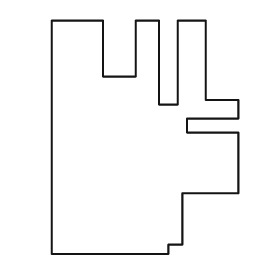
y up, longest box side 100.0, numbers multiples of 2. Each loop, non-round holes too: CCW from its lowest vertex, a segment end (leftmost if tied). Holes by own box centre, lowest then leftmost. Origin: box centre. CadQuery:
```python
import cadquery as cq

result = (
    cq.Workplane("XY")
    .moveTo(-40.0, -50.0)
    .lineTo(10.0, -50.0)
    .lineTo(10.0, -46.0)
    .lineTo(16.0, -46.0)
    .lineTo(16.0, -24.0)
    .lineTo(40.0, -24.0)
    .lineTo(40.0, 2.0)
    .lineTo(18.0, 2.0)
    .lineTo(18.0, 8.0)
    .lineTo(40.0, 8.0)
    .lineTo(40.0, 16.0)
    .lineTo(26.0, 16.0)
    .lineTo(26.0, 50.0)
    .lineTo(14.0, 50.0)
    .lineTo(14.0, 14.0)
    .lineTo(6.0, 14.0)
    .lineTo(6.0, 50.0)
    .lineTo(-4.0, 50.0)
    .lineTo(-4.0, 26.0)
    .lineTo(-18.0, 26.0)
    .lineTo(-18.0, 50.0)
    .lineTo(-40.0, 50.0)
    .close()
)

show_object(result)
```